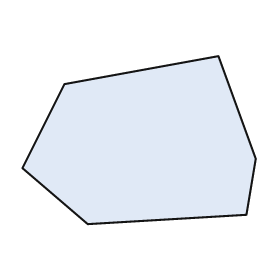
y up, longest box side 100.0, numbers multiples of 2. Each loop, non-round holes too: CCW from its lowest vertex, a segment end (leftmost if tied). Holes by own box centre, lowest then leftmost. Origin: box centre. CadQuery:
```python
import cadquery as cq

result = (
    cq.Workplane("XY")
    .moveTo(-22.0, -36.0)
    .lineTo(46.0, -32.0)
    .lineTo(50.0, -8.0)
    .lineTo(34.0, 36.0)
    .lineTo(-32.0, 24.0)
    .lineTo(-50.0, -12.0)
    .close()
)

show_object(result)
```